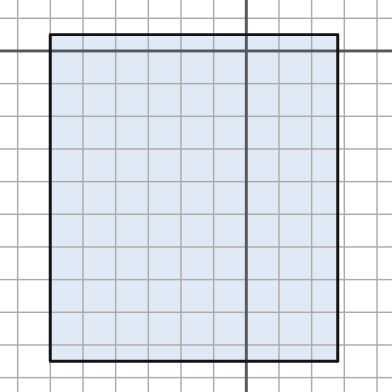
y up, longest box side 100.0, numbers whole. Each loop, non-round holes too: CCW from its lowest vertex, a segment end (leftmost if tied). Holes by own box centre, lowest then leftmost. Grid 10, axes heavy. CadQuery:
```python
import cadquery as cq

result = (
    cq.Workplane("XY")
    .moveTo(-60.0, -95.0)
    .lineTo(28.0, -95.0)
    .lineTo(28.0, 5.0)
    .lineTo(-60.0, 5.0)
    .close()
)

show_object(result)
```